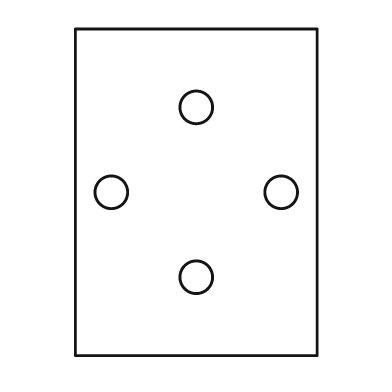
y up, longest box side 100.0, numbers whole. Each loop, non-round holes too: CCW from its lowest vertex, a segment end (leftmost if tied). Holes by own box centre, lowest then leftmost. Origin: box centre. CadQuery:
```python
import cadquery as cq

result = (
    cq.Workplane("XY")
    .moveTo(-37.0, -50.0)
    .lineTo(37.0, -50.0)
    .lineTo(37.0, 50.0)
    .lineTo(-37.0, 50.0)
    .close()
    .moveTo(0.0, -26.0)
    .circle(5.0)
    .moveTo(-26.0, 0.0)
    .circle(5.0)
    .moveTo(26.0, 0.0)
    .circle(5.0)
    .moveTo(0.0, 26.0)
    .circle(5.0)
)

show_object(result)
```